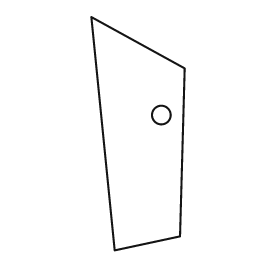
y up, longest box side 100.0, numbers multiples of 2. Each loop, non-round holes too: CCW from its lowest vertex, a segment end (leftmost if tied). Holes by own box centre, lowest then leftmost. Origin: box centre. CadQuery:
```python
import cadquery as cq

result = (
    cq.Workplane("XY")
    .moveTo(-10.0, -50.0)
    .lineTo(18.0, -44.0)
    .lineTo(20.0, 28.0)
    .lineTo(-20.0, 50.0)
    .close()
    .moveTo(10.0, 8.0)
    .circle(4.0)
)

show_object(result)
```